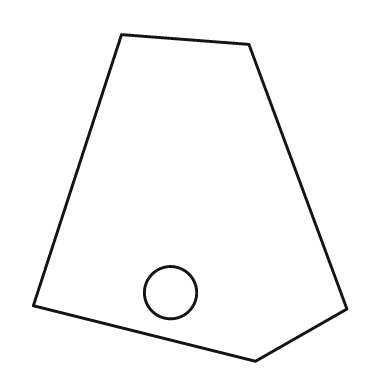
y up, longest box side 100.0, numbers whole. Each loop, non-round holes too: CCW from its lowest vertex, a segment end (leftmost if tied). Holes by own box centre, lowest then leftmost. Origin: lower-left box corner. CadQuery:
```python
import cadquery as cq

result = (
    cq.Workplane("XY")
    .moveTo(68.0, 0.0)
    .lineTo(96.0, 16.0)
    .lineTo(66.0, 97.0)
    .lineTo(27.0, 100.0)
    .lineTo(0.0, 17.0)
    .close()
    .moveTo(42.0, 21.0)
    .circle(8.0)
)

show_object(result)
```